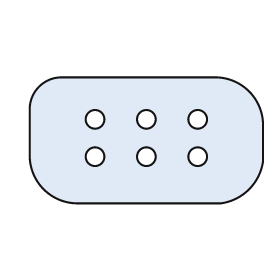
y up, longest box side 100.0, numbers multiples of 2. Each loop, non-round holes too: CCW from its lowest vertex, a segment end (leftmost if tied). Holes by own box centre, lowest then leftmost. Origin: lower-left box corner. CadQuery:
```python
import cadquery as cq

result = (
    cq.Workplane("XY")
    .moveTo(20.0, 0.0)
    .lineTo(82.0, 0.0)
    .threePointArc((94.0, 6.0), (100.0, 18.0))
    .lineTo(100.0, 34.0)
    .threePointArc((94.0, 48.0), (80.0, 54.0))
    .lineTo(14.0, 54.0)
    .threePointArc((4.0, 50.0), (0.0, 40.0))
    .lineTo(0.0, 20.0)
    .threePointArc((6.0, 6.0), (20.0, 0.0))
    .close()
    .moveTo(28.0, 20.0)
    .circle(4.0)
    .moveTo(50.0, 20.0)
    .circle(4.0)
    .moveTo(72.0, 20.0)
    .circle(4.0)
    .moveTo(28.0, 36.0)
    .circle(4.0)
    .moveTo(50.0, 36.0)
    .circle(4.0)
    .moveTo(72.0, 36.0)
    .circle(4.0)
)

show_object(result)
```